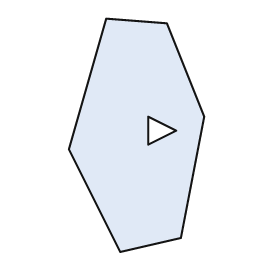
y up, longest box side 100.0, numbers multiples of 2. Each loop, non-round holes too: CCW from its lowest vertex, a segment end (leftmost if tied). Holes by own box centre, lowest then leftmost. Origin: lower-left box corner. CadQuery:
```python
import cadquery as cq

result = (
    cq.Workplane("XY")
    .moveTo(22.0, 0.0)
    .lineTo(48.0, 6.0)
    .lineTo(58.0, 58.0)
    .lineTo(42.0, 98.0)
    .lineTo(16.0, 100.0)
    .lineTo(0.0, 44.0)
    .close()
    .moveTo(34.0, 46.0)
    .lineTo(46.0, 52.0)
    .lineTo(34.0, 58.0)
    .close()
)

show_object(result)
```